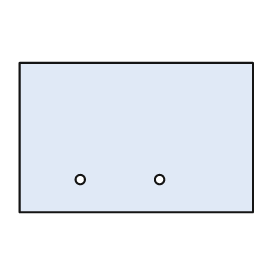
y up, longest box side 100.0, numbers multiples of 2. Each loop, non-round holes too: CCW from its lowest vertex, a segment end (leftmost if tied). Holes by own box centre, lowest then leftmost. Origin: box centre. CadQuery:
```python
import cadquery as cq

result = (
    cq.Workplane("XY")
    .moveTo(-50.0, -32.0)
    .lineTo(50.0, -32.0)
    .lineTo(50.0, 32.0)
    .lineTo(-50.0, 32.0)
    .close()
    .moveTo(-24.0, -18.0)
    .circle(2.0)
    .moveTo(10.0, -18.0)
    .circle(2.0)
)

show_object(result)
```